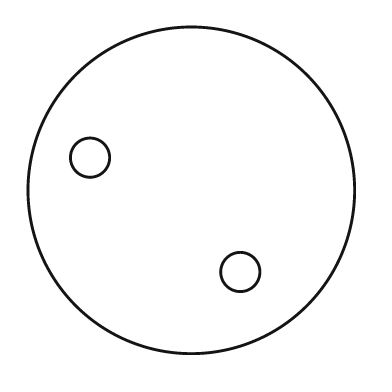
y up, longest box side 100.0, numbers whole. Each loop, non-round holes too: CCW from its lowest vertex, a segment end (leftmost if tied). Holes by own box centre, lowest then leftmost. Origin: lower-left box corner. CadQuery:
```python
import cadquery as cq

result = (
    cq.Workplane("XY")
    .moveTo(50.0, 50.0)
    .circle(50.0)
    .moveTo(65.0, 25.0)
    .circle(6.0)
    .moveTo(19.0, 60.0)
    .circle(6.0)
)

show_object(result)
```